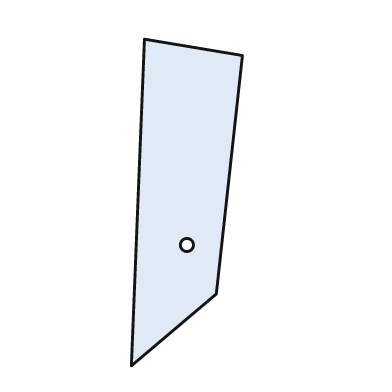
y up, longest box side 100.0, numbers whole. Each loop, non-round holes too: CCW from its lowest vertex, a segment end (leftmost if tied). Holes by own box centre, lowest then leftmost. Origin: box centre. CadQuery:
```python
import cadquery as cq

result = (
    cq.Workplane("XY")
    .moveTo(-17.0, -50.0)
    .lineTo(9.0, -28.0)
    .lineTo(17.0, 45.0)
    .lineTo(-13.0, 50.0)
    .close()
    .moveTo(0.0, -13.0)
    .circle(2.0)
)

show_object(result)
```